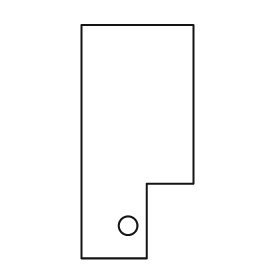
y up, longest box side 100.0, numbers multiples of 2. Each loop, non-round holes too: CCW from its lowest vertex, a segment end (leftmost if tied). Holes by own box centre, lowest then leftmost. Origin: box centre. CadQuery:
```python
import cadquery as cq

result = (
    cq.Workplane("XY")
    .moveTo(-24.0, -50.0)
    .lineTo(4.0, -50.0)
    .lineTo(4.0, -18.0)
    .lineTo(24.0, -18.0)
    .lineTo(24.0, 50.0)
    .lineTo(-24.0, 50.0)
    .close()
    .moveTo(-4.0, -36.0)
    .circle(4.0)
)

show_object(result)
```